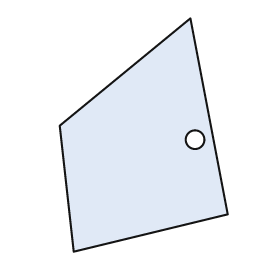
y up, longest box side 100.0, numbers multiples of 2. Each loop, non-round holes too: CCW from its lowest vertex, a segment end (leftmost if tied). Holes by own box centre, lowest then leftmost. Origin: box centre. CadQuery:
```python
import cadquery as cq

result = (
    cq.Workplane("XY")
    .moveTo(-30.0, -50.0)
    .lineTo(36.0, -34.0)
    .lineTo(20.0, 50.0)
    .lineTo(-36.0, 4.0)
    .close()
    .moveTo(22.0, -2.0)
    .circle(4.0)
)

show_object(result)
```